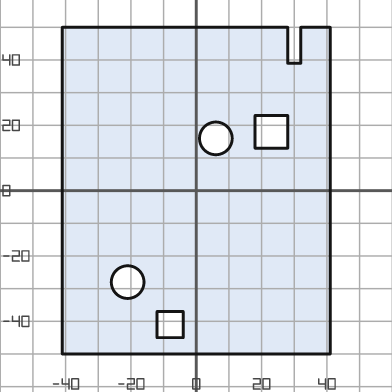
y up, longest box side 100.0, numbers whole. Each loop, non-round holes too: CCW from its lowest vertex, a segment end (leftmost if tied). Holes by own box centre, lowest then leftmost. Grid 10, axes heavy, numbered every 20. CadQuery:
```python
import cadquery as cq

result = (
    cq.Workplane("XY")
    .moveTo(-41.0, -50.0)
    .lineTo(41.0, -50.0)
    .lineTo(41.0, 50.0)
    .lineTo(32.0, 50.0)
    .lineTo(32.0, 39.0)
    .lineTo(28.0, 39.0)
    .lineTo(28.0, 50.0)
    .lineTo(-41.0, 50.0)
    .close()
    .moveTo(-12.0, -45.0)
    .lineTo(-4.0, -45.0)
    .lineTo(-4.0, -37.0)
    .lineTo(-12.0, -37.0)
    .close()
    .moveTo(-21.0, -28.0)
    .circle(5.0)
    .moveTo(6.0, 16.0)
    .circle(5.0)
    .moveTo(18.0, 13.0)
    .lineTo(28.0, 13.0)
    .lineTo(28.0, 23.0)
    .lineTo(18.0, 23.0)
    .close()
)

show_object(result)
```